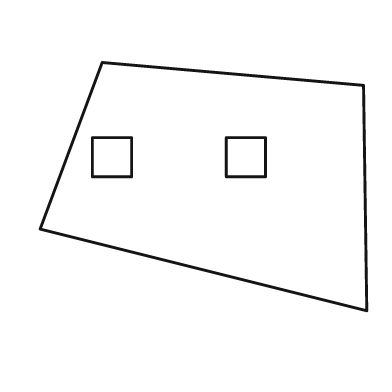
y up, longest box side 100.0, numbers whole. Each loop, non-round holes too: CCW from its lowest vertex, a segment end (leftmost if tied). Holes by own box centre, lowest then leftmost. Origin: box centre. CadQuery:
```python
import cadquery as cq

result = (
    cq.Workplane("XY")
    .moveTo(50.0, -38.0)
    .lineTo(49.0, 31.0)
    .lineTo(-31.0, 38.0)
    .lineTo(-50.0, -13.0)
    .close()
    .moveTo(-34.0, 3.0)
    .lineTo(-22.0, 3.0)
    .lineTo(-22.0, 15.0)
    .lineTo(-34.0, 15.0)
    .close()
    .moveTo(7.0, 3.0)
    .lineTo(19.0, 3.0)
    .lineTo(19.0, 15.0)
    .lineTo(7.0, 15.0)
    .close()
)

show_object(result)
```